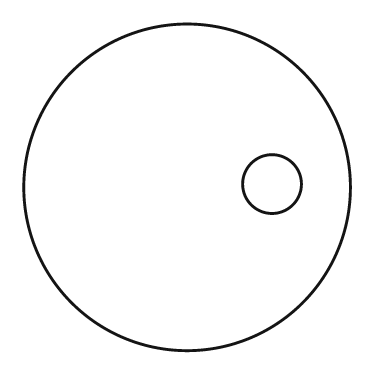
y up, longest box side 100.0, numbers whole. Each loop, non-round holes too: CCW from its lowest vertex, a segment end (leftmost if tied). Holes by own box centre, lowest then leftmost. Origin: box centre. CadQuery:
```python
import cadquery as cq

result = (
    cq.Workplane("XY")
    .moveTo(0.0, 0.0)
    .circle(50.0)
    .moveTo(26.0, 1.0)
    .circle(9.0)
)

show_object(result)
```